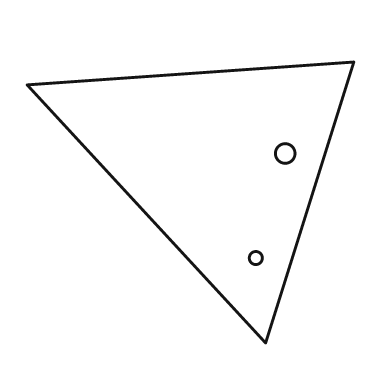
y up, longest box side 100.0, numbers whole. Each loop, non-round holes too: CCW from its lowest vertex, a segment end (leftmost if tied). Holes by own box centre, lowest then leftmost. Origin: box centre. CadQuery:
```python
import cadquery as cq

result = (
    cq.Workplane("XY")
    .moveTo(23.0, -43.0)
    .lineTo(50.0, 43.0)
    .lineTo(-50.0, 36.0)
    .close()
    .moveTo(20.0, -17.0)
    .circle(2.0)
    .moveTo(29.0, 15.0)
    .circle(3.0)
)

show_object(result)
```